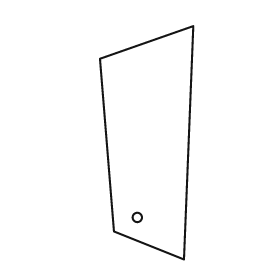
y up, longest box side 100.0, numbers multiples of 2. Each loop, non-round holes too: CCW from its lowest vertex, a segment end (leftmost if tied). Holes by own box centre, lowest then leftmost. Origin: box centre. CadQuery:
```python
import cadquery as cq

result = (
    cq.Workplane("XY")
    .moveTo(16.0, -50.0)
    .lineTo(20.0, 50.0)
    .lineTo(-20.0, 36.0)
    .lineTo(-14.0, -38.0)
    .close()
    .moveTo(-4.0, -32.0)
    .circle(2.0)
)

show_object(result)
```